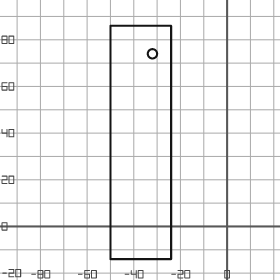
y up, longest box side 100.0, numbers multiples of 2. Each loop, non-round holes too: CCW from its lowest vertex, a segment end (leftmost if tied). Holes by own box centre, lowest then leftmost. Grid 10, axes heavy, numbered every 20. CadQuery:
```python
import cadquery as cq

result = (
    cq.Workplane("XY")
    .moveTo(-50.0, -14.0)
    .lineTo(-24.0, -14.0)
    .lineTo(-24.0, 86.0)
    .lineTo(-50.0, 86.0)
    .close()
    .moveTo(-32.0, 74.0)
    .circle(2.0)
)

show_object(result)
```